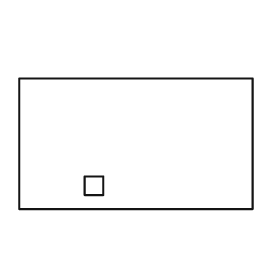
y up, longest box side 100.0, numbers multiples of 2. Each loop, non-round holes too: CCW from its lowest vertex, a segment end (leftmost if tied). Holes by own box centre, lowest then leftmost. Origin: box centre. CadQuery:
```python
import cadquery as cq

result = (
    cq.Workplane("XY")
    .moveTo(-50.0, -28.0)
    .lineTo(50.0, -28.0)
    .lineTo(50.0, 28.0)
    .lineTo(-50.0, 28.0)
    .close()
    .moveTo(-22.0, -22.0)
    .lineTo(-14.0, -22.0)
    .lineTo(-14.0, -14.0)
    .lineTo(-22.0, -14.0)
    .close()
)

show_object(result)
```